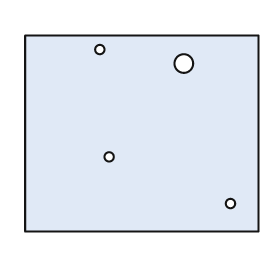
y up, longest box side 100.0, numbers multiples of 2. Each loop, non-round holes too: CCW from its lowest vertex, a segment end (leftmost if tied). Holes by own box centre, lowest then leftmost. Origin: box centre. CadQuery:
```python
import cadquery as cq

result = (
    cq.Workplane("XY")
    .moveTo(-50.0, -42.0)
    .lineTo(50.0, -42.0)
    .lineTo(50.0, 42.0)
    .lineTo(-50.0, 42.0)
    .close()
    .moveTo(38.0, -30.0)
    .circle(2.0)
    .moveTo(-14.0, -10.0)
    .circle(2.0)
    .moveTo(18.0, 30.0)
    .circle(4.0)
    .moveTo(-18.0, 36.0)
    .circle(2.0)
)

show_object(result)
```